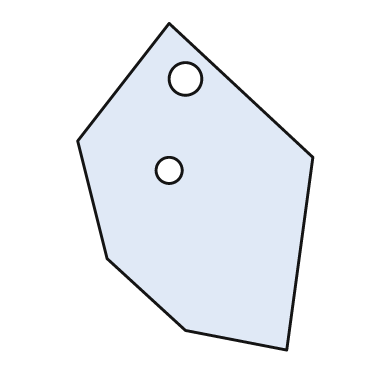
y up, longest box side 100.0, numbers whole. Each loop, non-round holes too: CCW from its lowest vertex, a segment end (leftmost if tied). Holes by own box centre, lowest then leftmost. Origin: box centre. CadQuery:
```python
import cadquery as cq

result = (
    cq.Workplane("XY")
    .moveTo(28.0, -50.0)
    .lineTo(36.0, 9.0)
    .lineTo(-8.0, 50.0)
    .lineTo(-36.0, 14.0)
    .lineTo(-27.0, -22.0)
    .lineTo(-3.0, -44.0)
    .close()
    .moveTo(-8.0, 5.0)
    .circle(4.0)
    .moveTo(-3.0, 33.0)
    .circle(5.0)
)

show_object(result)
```